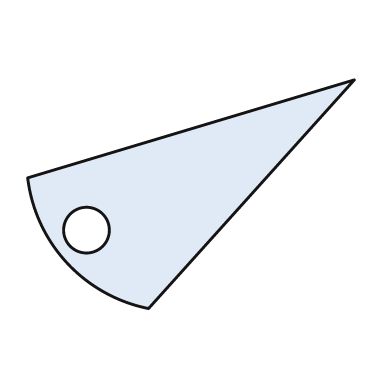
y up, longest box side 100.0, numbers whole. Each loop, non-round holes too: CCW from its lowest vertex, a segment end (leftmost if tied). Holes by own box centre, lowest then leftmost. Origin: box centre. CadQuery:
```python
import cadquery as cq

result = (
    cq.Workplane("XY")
    .moveTo(-13.0, -35.0)
    .lineTo(50.0, 35.0)
    .lineTo(-50.0, 5.0)
    .threePointArc((-38.0, -21.0), (-13.0, -35.0))
    .close()
    .moveTo(-32.0, -11.0)
    .circle(7.0)
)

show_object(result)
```